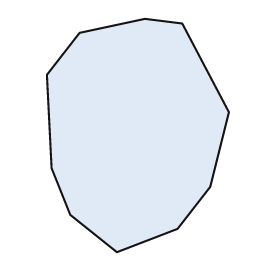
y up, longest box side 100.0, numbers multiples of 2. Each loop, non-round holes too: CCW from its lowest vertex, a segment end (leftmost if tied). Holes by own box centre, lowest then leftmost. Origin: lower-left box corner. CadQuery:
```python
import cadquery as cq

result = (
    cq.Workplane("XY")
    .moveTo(30.0, 0.0)
    .lineTo(56.0, 10.0)
    .lineTo(70.0, 28.0)
    .lineTo(78.0, 60.0)
    .lineTo(58.0, 98.0)
    .lineTo(42.0, 100.0)
    .lineTo(14.0, 94.0)
    .lineTo(0.0, 76.0)
    .lineTo(2.0, 36.0)
    .lineTo(10.0, 16.0)
    .close()
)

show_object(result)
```